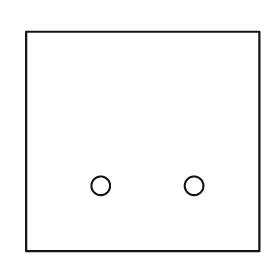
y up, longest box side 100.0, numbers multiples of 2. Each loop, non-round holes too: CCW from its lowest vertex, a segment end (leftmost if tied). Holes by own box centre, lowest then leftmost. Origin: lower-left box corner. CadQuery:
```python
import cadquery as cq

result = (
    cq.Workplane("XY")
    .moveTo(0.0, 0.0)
    .lineTo(100.0, 0.0)
    .lineTo(100.0, 94.0)
    .lineTo(0.0, 94.0)
    .close()
    .moveTo(32.0, 28.0)
    .circle(4.0)
    .moveTo(72.0, 28.0)
    .circle(4.0)
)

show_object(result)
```